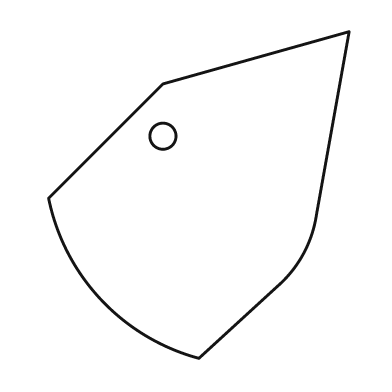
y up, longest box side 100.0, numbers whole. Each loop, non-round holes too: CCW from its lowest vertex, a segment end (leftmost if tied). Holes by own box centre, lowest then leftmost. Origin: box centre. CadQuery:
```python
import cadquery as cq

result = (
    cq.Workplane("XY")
    .moveTo(0.0, -50.0)
    .lineTo(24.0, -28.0)
    .threePointArc((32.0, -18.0), (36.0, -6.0))
    .lineTo(46.0, 50.0)
    .lineTo(-11.0, 34.0)
    .lineTo(-46.0, -1.0)
    .threePointArc((-30.0, -32.0), (0.0, -50.0))
    .close()
    .moveTo(-11.0, 18.0)
    .circle(4.0)
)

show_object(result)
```